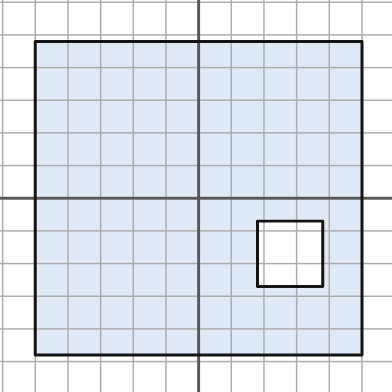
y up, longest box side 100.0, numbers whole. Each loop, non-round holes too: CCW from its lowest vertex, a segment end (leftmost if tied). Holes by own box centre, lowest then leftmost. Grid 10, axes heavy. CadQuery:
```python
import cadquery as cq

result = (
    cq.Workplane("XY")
    .moveTo(-50.0, -48.0)
    .lineTo(50.0, -48.0)
    .lineTo(50.0, 48.0)
    .lineTo(-50.0, 48.0)
    .close()
    .moveTo(18.0, -27.0)
    .lineTo(38.0, -27.0)
    .lineTo(38.0, -7.0)
    .lineTo(18.0, -7.0)
    .close()
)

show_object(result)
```